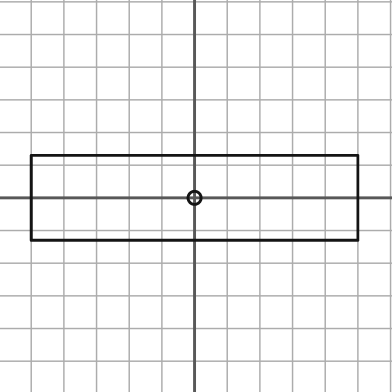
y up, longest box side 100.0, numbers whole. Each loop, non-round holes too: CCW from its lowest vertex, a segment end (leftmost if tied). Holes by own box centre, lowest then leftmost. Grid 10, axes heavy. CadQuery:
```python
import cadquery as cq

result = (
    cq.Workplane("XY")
    .moveTo(-50.0, -13.0)
    .lineTo(50.0, -13.0)
    .lineTo(50.0, 13.0)
    .lineTo(-50.0, 13.0)
    .close()
    .moveTo(0.0, 0.0)
    .circle(2.0)
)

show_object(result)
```